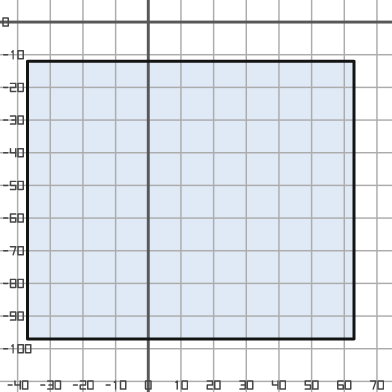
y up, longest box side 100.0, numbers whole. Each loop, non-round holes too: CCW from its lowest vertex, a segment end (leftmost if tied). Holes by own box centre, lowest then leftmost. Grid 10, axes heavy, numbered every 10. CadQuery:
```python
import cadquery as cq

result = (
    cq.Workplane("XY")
    .moveTo(-37.0, -97.0)
    .lineTo(63.0, -97.0)
    .lineTo(63.0, -12.0)
    .lineTo(-37.0, -12.0)
    .close()
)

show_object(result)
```